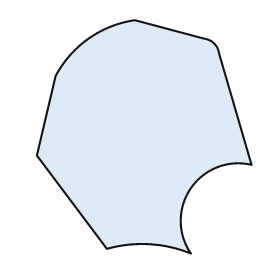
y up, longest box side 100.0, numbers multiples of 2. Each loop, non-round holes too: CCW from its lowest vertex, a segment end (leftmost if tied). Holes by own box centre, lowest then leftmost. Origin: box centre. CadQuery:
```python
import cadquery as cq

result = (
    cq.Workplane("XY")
    .moveTo(20.0, -50.0)
    .threePointArc((20.0, -22.0), (46.0, -12.0))
    .lineTo(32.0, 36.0)
    .threePointArc((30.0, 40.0), (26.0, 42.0))
    .lineTo(-4.0, 50.0)
    .threePointArc((-24.0, 42.0), (-38.0, 26.0))
    .lineTo(-46.0, -8.0)
    .lineTo(-16.0, -48.0)
    .threePointArc((2.0, -46.0), (20.0, -50.0))
    .close()
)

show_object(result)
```